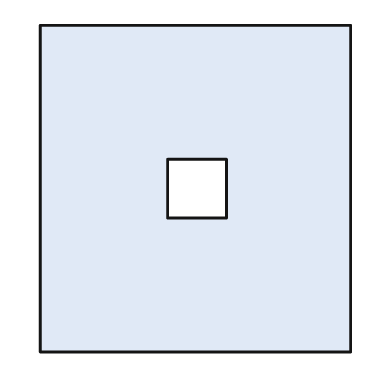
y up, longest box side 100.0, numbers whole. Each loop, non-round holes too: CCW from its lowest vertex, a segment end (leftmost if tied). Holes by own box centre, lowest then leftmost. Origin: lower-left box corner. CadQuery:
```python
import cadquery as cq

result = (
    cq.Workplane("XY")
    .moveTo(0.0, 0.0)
    .lineTo(95.0, 0.0)
    .lineTo(95.0, 100.0)
    .lineTo(0.0, 100.0)
    .close()
    .moveTo(39.0, 41.0)
    .lineTo(57.0, 41.0)
    .lineTo(57.0, 59.0)
    .lineTo(39.0, 59.0)
    .close()
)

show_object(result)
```